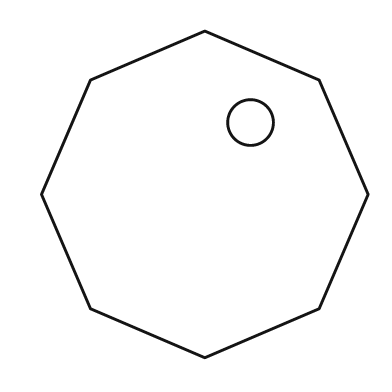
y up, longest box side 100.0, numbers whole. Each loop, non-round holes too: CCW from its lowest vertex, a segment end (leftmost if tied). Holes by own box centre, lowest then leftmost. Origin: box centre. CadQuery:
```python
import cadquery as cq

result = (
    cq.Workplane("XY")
    .moveTo(0.0, -50.0)
    .lineTo(35.0, -35.0)
    .lineTo(50.0, 0.0)
    .lineTo(35.0, 35.0)
    .lineTo(0.0, 50.0)
    .lineTo(-35.0, 35.0)
    .lineTo(-50.0, 0.0)
    .lineTo(-35.0, -35.0)
    .close()
    .moveTo(14.0, 22.0)
    .circle(7.0)
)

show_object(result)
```